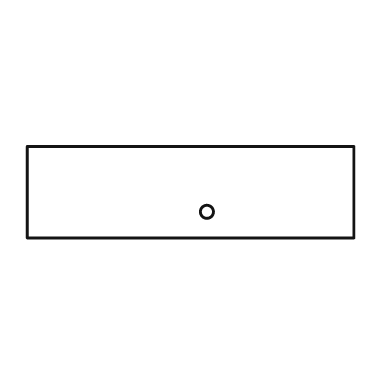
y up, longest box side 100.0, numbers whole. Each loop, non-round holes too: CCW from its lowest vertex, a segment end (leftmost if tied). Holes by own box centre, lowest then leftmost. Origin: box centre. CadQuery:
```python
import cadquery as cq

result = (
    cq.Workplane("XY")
    .moveTo(-50.0, -14.0)
    .lineTo(50.0, -14.0)
    .lineTo(50.0, 14.0)
    .lineTo(-50.0, 14.0)
    .close()
    .moveTo(5.0, -6.0)
    .circle(2.0)
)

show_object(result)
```